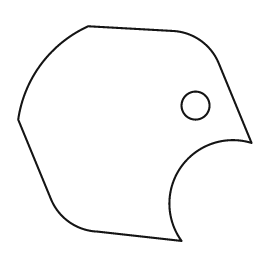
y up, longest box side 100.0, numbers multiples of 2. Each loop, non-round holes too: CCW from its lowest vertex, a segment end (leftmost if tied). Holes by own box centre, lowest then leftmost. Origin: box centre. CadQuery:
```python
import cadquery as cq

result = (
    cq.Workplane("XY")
    .moveTo(20.0, -46.0)
    .threePointArc((20.0, -14.0), (50.0, -4.0))
    .lineTo(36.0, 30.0)
    .threePointArc((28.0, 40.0), (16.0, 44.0))
    .lineTo(-20.0, 46.0)
    .threePointArc((-40.0, 30.0), (-50.0, 6.0))
    .lineTo(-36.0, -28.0)
    .threePointArc((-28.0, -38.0), (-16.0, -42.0))
    .close()
    .moveTo(26.0, 12.0)
    .circle(6.0)
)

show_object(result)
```